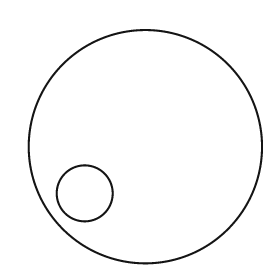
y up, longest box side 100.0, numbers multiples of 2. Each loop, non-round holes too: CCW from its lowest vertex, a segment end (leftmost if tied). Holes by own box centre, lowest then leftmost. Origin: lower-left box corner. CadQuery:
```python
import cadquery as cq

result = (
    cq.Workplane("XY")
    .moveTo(50.0, 50.0)
    .circle(50.0)
    .moveTo(24.0, 30.0)
    .circle(12.0)
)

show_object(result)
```